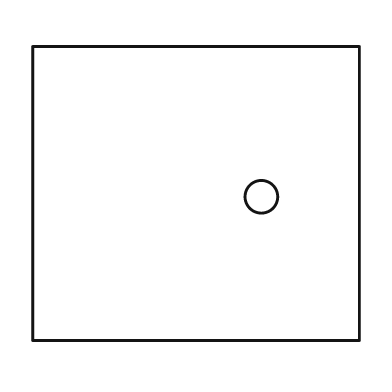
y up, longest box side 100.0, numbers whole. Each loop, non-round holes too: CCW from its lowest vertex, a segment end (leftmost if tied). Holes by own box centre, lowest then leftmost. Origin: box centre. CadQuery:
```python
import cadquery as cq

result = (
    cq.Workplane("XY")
    .moveTo(-50.0, -45.0)
    .lineTo(50.0, -45.0)
    .lineTo(50.0, 45.0)
    .lineTo(-50.0, 45.0)
    .close()
    .moveTo(20.0, -1.0)
    .circle(5.0)
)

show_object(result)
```